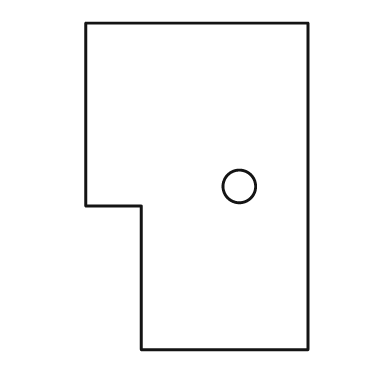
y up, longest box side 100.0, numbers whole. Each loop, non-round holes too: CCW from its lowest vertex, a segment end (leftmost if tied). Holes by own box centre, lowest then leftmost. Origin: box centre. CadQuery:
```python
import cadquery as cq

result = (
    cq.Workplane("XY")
    .moveTo(-17.0, -50.0)
    .lineTo(34.0, -50.0)
    .lineTo(34.0, 50.0)
    .lineTo(-34.0, 50.0)
    .lineTo(-34.0, -6.0)
    .lineTo(-17.0, -6.0)
    .close()
    .moveTo(13.0, 0.0)
    .circle(5.0)
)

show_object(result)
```